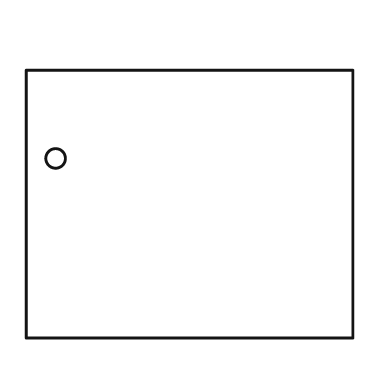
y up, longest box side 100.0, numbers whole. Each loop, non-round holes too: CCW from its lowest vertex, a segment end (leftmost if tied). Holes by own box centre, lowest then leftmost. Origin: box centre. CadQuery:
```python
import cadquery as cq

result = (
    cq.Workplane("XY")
    .moveTo(-50.0, -41.0)
    .lineTo(50.0, -41.0)
    .lineTo(50.0, 41.0)
    .lineTo(-50.0, 41.0)
    .close()
    .moveTo(-41.0, 14.0)
    .circle(3.0)
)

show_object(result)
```